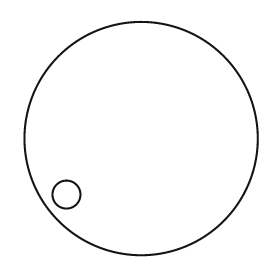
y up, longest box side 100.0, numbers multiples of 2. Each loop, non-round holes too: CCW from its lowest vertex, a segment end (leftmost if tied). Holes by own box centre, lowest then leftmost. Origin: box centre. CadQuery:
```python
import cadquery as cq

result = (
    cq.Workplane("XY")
    .moveTo(0.0, 0.0)
    .circle(50.0)
    .moveTo(-32.0, -24.0)
    .circle(6.0)
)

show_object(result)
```